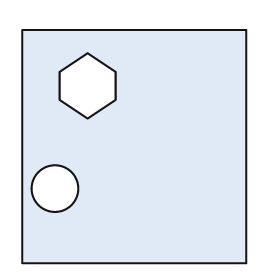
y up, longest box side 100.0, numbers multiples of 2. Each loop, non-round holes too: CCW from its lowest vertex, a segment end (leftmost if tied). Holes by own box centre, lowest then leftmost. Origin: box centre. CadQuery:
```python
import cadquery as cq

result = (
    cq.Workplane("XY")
    .moveTo(-48.0, -50.0)
    .lineTo(48.0, -50.0)
    .lineTo(48.0, 50.0)
    .lineTo(-48.0, 50.0)
    .close()
    .moveTo(-34.0, -18.0)
    .circle(10.0)
    .moveTo(-20.0, 12.0)
    .lineTo(-8.0, 20.0)
    .lineTo(-8.0, 32.0)
    .lineTo(-20.0, 40.0)
    .lineTo(-32.0, 32.0)
    .lineTo(-32.0, 20.0)
    .close()
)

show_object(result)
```